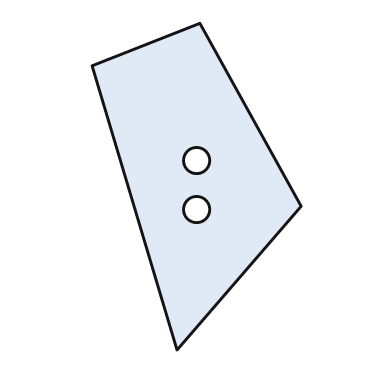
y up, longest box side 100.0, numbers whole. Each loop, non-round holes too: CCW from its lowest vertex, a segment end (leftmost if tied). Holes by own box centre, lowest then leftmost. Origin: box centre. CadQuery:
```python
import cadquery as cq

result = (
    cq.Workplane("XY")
    .moveTo(-6.0, -50.0)
    .lineTo(32.0, -6.0)
    .lineTo(1.0, 50.0)
    .lineTo(-32.0, 37.0)
    .close()
    .moveTo(0.0, -7.0)
    .circle(4.0)
    .moveTo(0.0, 8.0)
    .circle(4.0)
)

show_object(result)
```